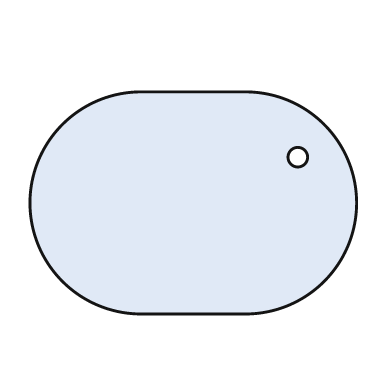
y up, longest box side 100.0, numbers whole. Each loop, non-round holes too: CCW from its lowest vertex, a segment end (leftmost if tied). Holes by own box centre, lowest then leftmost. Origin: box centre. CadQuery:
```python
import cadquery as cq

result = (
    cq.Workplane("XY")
    .moveTo(-16.0, -34.0)
    .lineTo(16.0, -34.0)
    .threePointArc((50.0, 0.0), (16.0, 34.0))
    .lineTo(-16.0, 34.0)
    .threePointArc((-50.0, 0.0), (-16.0, -34.0))
    .close()
    .moveTo(32.0, 14.0)
    .circle(3.0)
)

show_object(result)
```